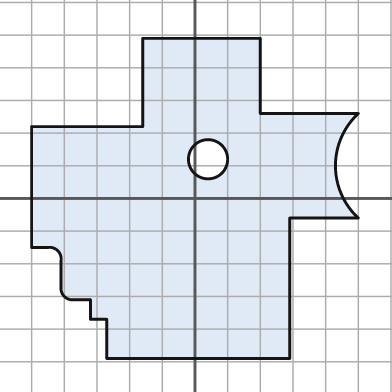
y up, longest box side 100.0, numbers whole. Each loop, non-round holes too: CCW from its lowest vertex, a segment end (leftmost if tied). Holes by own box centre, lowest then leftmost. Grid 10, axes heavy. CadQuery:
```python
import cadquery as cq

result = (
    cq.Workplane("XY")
    .moveTo(-27.0, -49.0)
    .lineTo(29.0, -49.0)
    .lineTo(29.0, -6.0)
    .lineTo(50.0, -6.0)
    .threePointArc((43.0, 10.0), (50.0, 26.0))
    .lineTo(20.0, 26.0)
    .lineTo(20.0, 49.0)
    .lineTo(-16.0, 49.0)
    .lineTo(-16.0, 22.0)
    .lineTo(-50.0, 22.0)
    .lineTo(-50.0, -15.0)
    .lineTo(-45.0, -15.0)
    .threePointArc((-42.0, -16.0), (-41.0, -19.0))
    .lineTo(-41.0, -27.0)
    .threePointArc((-40.0, -30.0), (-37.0, -31.0))
    .lineTo(-32.0, -31.0)
    .lineTo(-32.0, -37.0)
    .lineTo(-27.0, -37.0)
    .close()
    .moveTo(4.0, 12.0)
    .circle(6.0)
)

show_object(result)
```